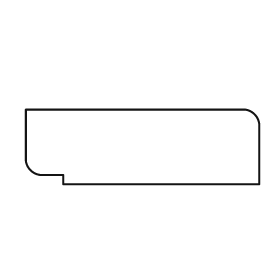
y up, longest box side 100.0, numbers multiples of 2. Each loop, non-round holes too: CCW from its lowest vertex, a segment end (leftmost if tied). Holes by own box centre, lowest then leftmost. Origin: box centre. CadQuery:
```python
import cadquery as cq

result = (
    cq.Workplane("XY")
    .moveTo(-34.0, -16.0)
    .lineTo(50.0, -16.0)
    .lineTo(50.0, 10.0)
    .threePointArc((48.0, 14.0), (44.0, 16.0))
    .lineTo(-50.0, 16.0)
    .lineTo(-50.0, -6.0)
    .threePointArc((-48.0, -10.0), (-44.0, -12.0))
    .lineTo(-34.0, -12.0)
    .close()
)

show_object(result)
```